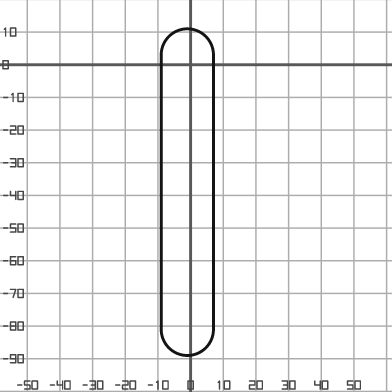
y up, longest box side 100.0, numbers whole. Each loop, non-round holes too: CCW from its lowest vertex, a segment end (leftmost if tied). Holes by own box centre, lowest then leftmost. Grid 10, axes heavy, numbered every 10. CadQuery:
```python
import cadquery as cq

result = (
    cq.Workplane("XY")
    .moveTo(-9.0, -81.0)
    .threePointArc((-1.0, -89.0), (7.0, -81.0))
    .lineTo(7.0, 3.0)
    .threePointArc((-1.0, 11.0), (-9.0, 3.0))
    .close()
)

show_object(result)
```